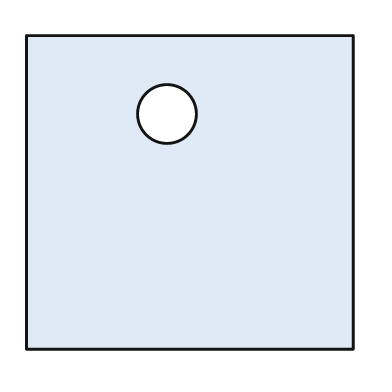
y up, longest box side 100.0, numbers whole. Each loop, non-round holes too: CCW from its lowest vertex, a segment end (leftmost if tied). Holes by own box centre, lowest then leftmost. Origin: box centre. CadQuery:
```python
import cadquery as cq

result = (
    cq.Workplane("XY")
    .moveTo(-50.0, -48.0)
    .lineTo(50.0, -48.0)
    .lineTo(50.0, 48.0)
    .lineTo(-50.0, 48.0)
    .close()
    .moveTo(-7.0, 24.0)
    .circle(9.0)
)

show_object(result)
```